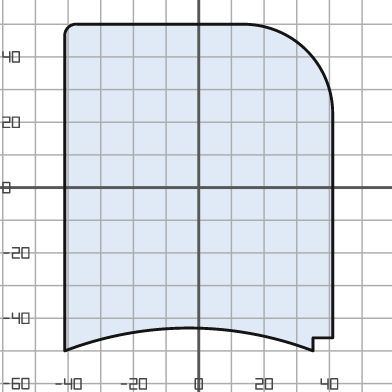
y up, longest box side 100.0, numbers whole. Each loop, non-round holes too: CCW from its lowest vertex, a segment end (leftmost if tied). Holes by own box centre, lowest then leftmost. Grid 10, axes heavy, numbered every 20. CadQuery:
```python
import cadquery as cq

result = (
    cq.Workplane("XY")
    .moveTo(-41.0, -50.0)
    .threePointArc((-3.0, -43.0), (35.0, -50.0))
    .lineTo(35.0, -46.0)
    .lineTo(41.0, -46.0)
    .lineTo(41.0, 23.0)
    .threePointArc((33.0, 42.0), (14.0, 50.0))
    .lineTo(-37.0, 50.0)
    .threePointArc((-40.0, 49.0), (-41.0, 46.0))
    .close()
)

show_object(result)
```